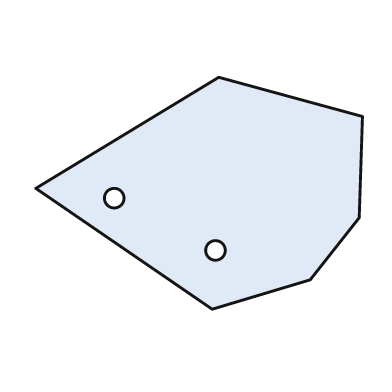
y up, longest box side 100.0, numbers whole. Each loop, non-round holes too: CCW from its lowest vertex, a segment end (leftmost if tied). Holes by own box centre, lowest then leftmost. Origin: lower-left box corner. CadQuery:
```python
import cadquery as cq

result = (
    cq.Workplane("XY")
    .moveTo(54.0, 0.0)
    .lineTo(84.0, 9.0)
    .lineTo(99.0, 28.0)
    .lineTo(100.0, 59.0)
    .lineTo(56.0, 71.0)
    .lineTo(0.0, 37.0)
    .close()
    .moveTo(55.0, 18.0)
    .circle(3.0)
    .moveTo(24.0, 34.0)
    .circle(3.0)
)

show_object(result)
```